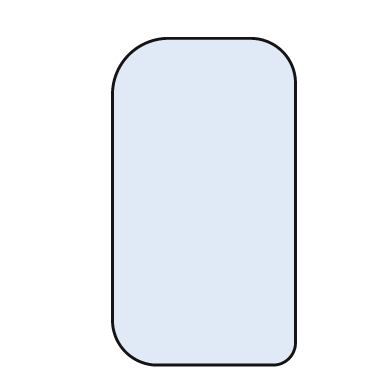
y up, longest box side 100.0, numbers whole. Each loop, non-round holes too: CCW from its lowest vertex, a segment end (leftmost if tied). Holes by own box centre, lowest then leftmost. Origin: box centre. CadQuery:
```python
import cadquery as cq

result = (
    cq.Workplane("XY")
    .moveTo(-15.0, -50.0)
    .lineTo(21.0, -50.0)
    .threePointArc((26.0, -48.0), (28.0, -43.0))
    .lineTo(28.0, 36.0)
    .threePointArc((24.0, 46.0), (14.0, 50.0))
    .lineTo(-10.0, 50.0)
    .threePointArc((-23.0, 45.0), (-28.0, 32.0))
    .lineTo(-28.0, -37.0)
    .threePointArc((-24.0, -46.0), (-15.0, -50.0))
    .close()
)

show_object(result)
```